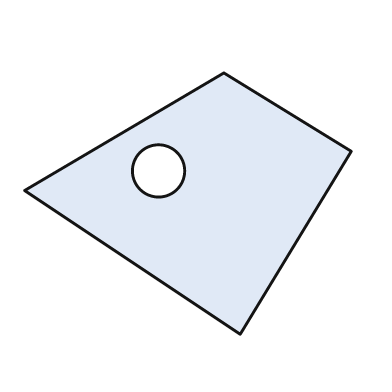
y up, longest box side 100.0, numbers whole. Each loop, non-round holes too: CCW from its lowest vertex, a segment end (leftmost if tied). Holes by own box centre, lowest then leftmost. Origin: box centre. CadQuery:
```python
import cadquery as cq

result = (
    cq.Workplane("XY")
    .moveTo(16.0, -40.0)
    .lineTo(50.0, 16.0)
    .lineTo(11.0, 40.0)
    .lineTo(-50.0, 4.0)
    .close()
    .moveTo(-9.0, 10.0)
    .circle(8.0)
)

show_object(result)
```